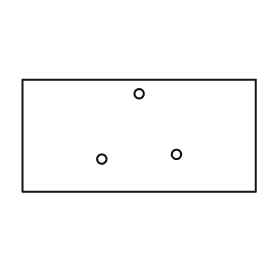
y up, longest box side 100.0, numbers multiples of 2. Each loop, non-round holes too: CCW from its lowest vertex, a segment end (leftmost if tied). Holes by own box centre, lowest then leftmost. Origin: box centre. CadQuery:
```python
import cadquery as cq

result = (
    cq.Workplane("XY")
    .moveTo(-50.0, -24.0)
    .lineTo(50.0, -24.0)
    .lineTo(50.0, 24.0)
    .lineTo(-50.0, 24.0)
    .close()
    .moveTo(-16.0, -10.0)
    .circle(2.0)
    .moveTo(16.0, -8.0)
    .circle(2.0)
    .moveTo(0.0, 18.0)
    .circle(2.0)
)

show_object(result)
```